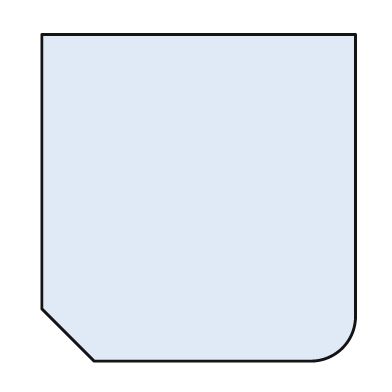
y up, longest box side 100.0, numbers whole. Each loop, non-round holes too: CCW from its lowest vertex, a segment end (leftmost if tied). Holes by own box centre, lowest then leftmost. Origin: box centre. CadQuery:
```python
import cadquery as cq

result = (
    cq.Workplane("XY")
    .moveTo(-32.0, -50.0)
    .lineTo(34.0, -50.0)
    .threePointArc((44.0, -46.0), (48.0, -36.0))
    .lineTo(48.0, 50.0)
    .lineTo(-48.0, 50.0)
    .lineTo(-48.0, -34.0)
    .close()
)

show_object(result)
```